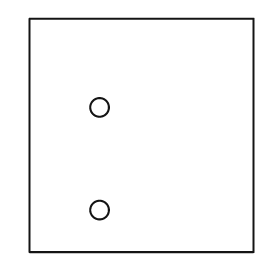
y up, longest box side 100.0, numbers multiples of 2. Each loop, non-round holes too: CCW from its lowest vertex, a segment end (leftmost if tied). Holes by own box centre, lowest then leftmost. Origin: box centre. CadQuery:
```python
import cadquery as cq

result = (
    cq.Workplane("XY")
    .moveTo(-48.0, -50.0)
    .lineTo(48.0, -50.0)
    .lineTo(48.0, 50.0)
    .lineTo(-48.0, 50.0)
    .close()
    .moveTo(-18.0, -32.0)
    .circle(4.0)
    .moveTo(-18.0, 12.0)
    .circle(4.0)
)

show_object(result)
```